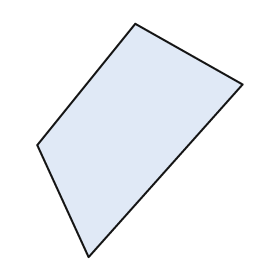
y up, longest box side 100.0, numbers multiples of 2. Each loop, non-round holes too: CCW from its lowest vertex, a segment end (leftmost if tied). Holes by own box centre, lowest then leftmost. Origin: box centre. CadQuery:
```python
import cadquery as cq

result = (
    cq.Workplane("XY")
    .moveTo(-22.0, -50.0)
    .lineTo(44.0, 24.0)
    .lineTo(-2.0, 50.0)
    .lineTo(-44.0, -2.0)
    .close()
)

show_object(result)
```